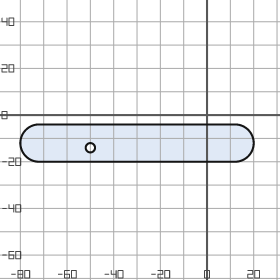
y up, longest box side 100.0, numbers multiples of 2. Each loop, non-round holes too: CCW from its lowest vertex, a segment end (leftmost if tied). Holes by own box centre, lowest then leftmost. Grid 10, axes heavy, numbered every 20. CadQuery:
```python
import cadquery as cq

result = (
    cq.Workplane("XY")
    .moveTo(-72.0, -20.0)
    .lineTo(12.0, -20.0)
    .threePointArc((20.0, -12.0), (12.0, -4.0))
    .lineTo(-72.0, -4.0)
    .threePointArc((-80.0, -12.0), (-72.0, -20.0))
    .close()
    .moveTo(-50.0, -14.0)
    .circle(2.0)
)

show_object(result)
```